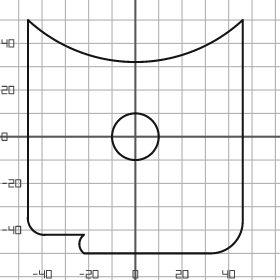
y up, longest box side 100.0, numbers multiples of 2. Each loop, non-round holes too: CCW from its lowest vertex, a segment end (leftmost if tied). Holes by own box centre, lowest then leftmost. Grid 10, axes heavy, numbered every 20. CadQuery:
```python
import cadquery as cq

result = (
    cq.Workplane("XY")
    .moveTo(-22.0, -50.0)
    .lineTo(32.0, -50.0)
    .threePointArc((42.0, -46.0), (46.0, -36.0))
    .lineTo(46.0, 50.0)
    .threePointArc((0.0, 32.0), (-46.0, 50.0))
    .lineTo(-46.0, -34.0)
    .threePointArc((-44.0, -40.0), (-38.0, -42.0))
    .lineTo(-22.0, -42.0)
    .threePointArc((-24.0, -46.0), (-22.0, -50.0))
    .close()
    .moveTo(0.0, 0.0)
    .circle(10.0)
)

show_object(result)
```